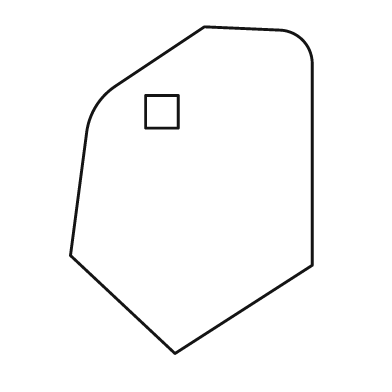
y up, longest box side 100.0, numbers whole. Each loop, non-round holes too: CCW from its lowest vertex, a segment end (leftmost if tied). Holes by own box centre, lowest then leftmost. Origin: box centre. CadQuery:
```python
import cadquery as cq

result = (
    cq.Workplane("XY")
    .moveTo(-5.0, -50.0)
    .lineTo(37.0, -23.0)
    .lineTo(37.0, 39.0)
    .threePointArc((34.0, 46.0), (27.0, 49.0))
    .lineTo(4.0, 50.0)
    .lineTo(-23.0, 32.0)
    .threePointArc((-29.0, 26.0), (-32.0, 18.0))
    .lineTo(-37.0, -20.0)
    .close()
    .moveTo(-14.0, 19.0)
    .lineTo(-4.0, 19.0)
    .lineTo(-4.0, 29.0)
    .lineTo(-14.0, 29.0)
    .close()
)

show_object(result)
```